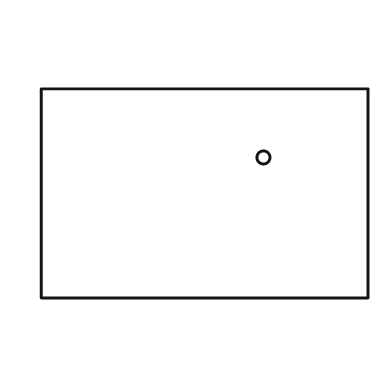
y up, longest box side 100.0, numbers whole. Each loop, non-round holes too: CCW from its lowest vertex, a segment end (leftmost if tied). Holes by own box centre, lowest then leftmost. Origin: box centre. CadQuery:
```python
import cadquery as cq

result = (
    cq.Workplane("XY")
    .moveTo(-50.0, -32.0)
    .lineTo(50.0, -32.0)
    .lineTo(50.0, 32.0)
    .lineTo(-50.0, 32.0)
    .close()
    .moveTo(18.0, 11.0)
    .circle(2.0)
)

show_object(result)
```